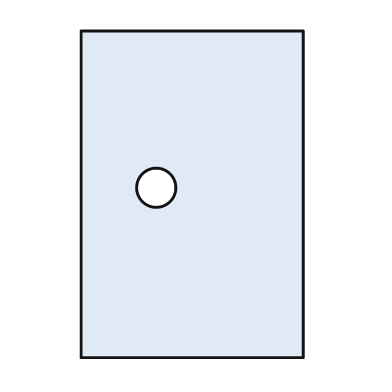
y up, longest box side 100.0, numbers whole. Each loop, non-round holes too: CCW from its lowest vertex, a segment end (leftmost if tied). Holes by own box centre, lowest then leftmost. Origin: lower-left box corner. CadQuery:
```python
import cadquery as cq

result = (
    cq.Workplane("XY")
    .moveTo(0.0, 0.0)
    .lineTo(68.0, 0.0)
    .lineTo(68.0, 100.0)
    .lineTo(0.0, 100.0)
    .close()
    .moveTo(23.0, 52.0)
    .circle(6.0)
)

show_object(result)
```